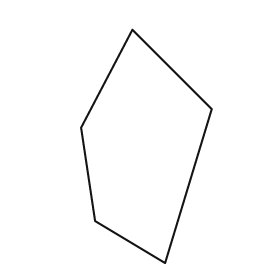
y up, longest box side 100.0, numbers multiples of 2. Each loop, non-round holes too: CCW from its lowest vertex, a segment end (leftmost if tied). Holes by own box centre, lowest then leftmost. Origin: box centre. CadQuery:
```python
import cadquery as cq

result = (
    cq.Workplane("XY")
    .moveTo(8.0, -50.0)
    .lineTo(28.0, 16.0)
    .lineTo(-6.0, 50.0)
    .lineTo(-28.0, 8.0)
    .lineTo(-22.0, -32.0)
    .close()
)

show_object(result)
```